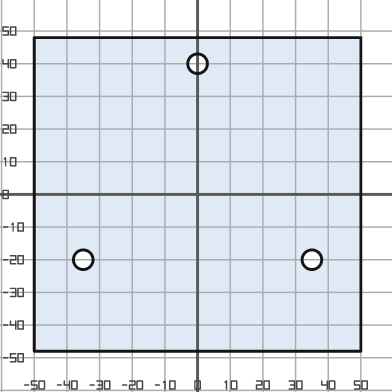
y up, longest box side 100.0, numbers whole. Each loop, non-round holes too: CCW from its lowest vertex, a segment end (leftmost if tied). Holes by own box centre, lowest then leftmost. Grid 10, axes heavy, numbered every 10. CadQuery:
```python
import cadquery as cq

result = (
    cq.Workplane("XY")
    .moveTo(-50.0, -48.0)
    .lineTo(50.0, -48.0)
    .lineTo(50.0, 48.0)
    .lineTo(-50.0, 48.0)
    .close()
    .moveTo(-35.0, -20.0)
    .circle(3.0)
    .moveTo(35.0, -20.0)
    .circle(3.0)
    .moveTo(0.0, 40.0)
    .circle(3.0)
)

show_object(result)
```